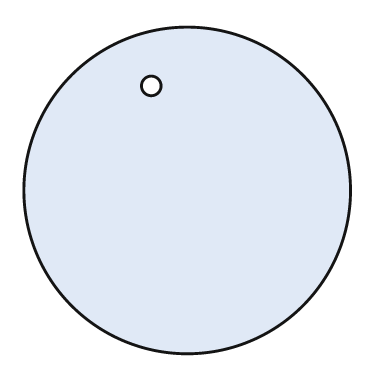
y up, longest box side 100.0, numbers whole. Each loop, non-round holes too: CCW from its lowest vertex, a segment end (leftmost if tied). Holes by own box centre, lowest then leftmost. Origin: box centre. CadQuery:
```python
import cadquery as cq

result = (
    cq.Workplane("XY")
    .moveTo(0.0, 0.0)
    .circle(50.0)
    .moveTo(-11.0, 32.0)
    .circle(3.0)
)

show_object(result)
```